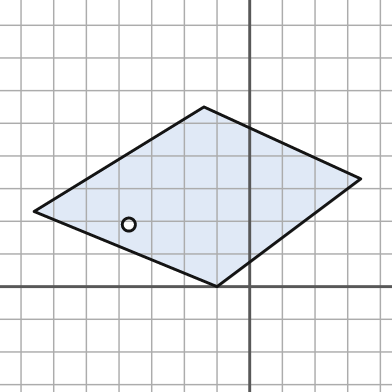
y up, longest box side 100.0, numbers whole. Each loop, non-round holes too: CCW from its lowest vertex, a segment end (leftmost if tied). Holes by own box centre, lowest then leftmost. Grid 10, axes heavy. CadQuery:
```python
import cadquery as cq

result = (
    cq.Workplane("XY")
    .moveTo(-10.0, 0.0)
    .lineTo(34.0, 33.0)
    .lineTo(-14.0, 55.0)
    .lineTo(-66.0, 23.0)
    .close()
    .moveTo(-37.0, 19.0)
    .circle(2.0)
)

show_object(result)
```